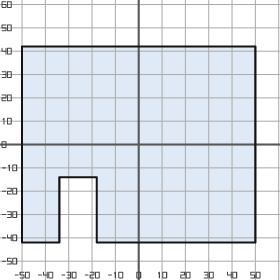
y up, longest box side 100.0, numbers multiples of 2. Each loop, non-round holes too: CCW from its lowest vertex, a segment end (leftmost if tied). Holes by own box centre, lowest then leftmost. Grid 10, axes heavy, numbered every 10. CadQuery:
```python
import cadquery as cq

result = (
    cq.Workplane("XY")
    .moveTo(-50.0, -42.0)
    .lineTo(-34.0, -42.0)
    .lineTo(-34.0, -14.0)
    .lineTo(-18.0, -14.0)
    .lineTo(-18.0, -42.0)
    .lineTo(50.0, -42.0)
    .lineTo(50.0, 42.0)
    .lineTo(-50.0, 42.0)
    .close()
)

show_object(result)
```